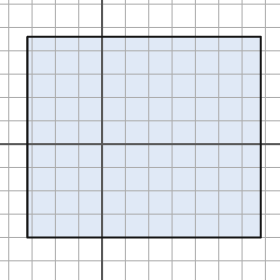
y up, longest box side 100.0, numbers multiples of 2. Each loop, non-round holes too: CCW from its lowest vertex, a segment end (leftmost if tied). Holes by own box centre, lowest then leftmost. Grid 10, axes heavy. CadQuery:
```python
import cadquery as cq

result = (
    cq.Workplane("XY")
    .moveTo(-32.0, -40.0)
    .lineTo(68.0, -40.0)
    .lineTo(68.0, 46.0)
    .lineTo(-32.0, 46.0)
    .close()
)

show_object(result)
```